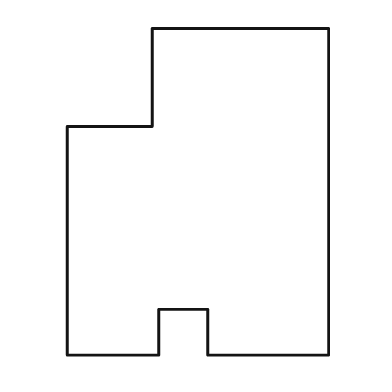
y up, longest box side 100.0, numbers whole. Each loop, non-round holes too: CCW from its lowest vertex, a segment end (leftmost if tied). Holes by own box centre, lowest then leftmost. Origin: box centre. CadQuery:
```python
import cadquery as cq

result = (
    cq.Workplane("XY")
    .moveTo(-40.0, -50.0)
    .lineTo(-12.0, -50.0)
    .lineTo(-12.0, -36.0)
    .lineTo(3.0, -36.0)
    .lineTo(3.0, -50.0)
    .lineTo(40.0, -50.0)
    .lineTo(40.0, 50.0)
    .lineTo(-14.0, 50.0)
    .lineTo(-14.0, 20.0)
    .lineTo(-40.0, 20.0)
    .close()
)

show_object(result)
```